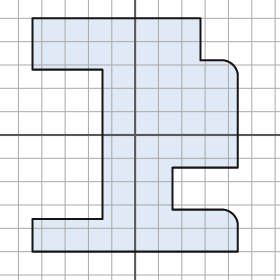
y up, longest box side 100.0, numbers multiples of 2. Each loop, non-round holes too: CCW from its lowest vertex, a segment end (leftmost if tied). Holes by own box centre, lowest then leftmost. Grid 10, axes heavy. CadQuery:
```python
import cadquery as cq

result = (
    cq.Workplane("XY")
    .moveTo(-44.0, -50.0)
    .lineTo(44.0, -50.0)
    .lineTo(44.0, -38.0)
    .threePointArc((42.0, -34.0), (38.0, -32.0))
    .lineTo(16.0, -32.0)
    .lineTo(16.0, -14.0)
    .lineTo(44.0, -14.0)
    .lineTo(44.0, 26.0)
    .threePointArc((42.0, 30.0), (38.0, 32.0))
    .lineTo(28.0, 32.0)
    .lineTo(28.0, 50.0)
    .lineTo(-44.0, 50.0)
    .lineTo(-44.0, 28.0)
    .lineTo(-14.0, 28.0)
    .lineTo(-14.0, -36.0)
    .lineTo(-44.0, -36.0)
    .close()
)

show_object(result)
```